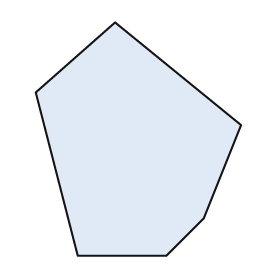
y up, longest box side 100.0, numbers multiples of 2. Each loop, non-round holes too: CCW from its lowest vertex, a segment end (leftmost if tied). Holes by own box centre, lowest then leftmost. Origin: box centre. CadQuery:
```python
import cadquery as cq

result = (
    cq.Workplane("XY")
    .moveTo(-26.0, -50.0)
    .lineTo(12.0, -50.0)
    .lineTo(28.0, -34.0)
    .lineTo(44.0, 6.0)
    .lineTo(-10.0, 50.0)
    .lineTo(-44.0, 20.0)
    .close()
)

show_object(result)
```